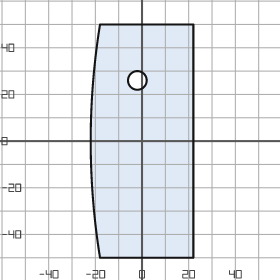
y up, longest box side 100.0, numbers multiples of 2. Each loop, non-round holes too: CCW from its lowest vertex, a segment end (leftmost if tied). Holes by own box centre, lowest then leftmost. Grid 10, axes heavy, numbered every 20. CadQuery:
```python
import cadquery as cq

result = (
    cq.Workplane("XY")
    .moveTo(-18.0, -50.0)
    .lineTo(22.0, -50.0)
    .lineTo(22.0, 50.0)
    .lineTo(-18.0, 50.0)
    .threePointArc((-22.0, 0.0), (-18.0, -50.0))
    .close()
    .moveTo(-2.0, 26.0)
    .circle(4.0)
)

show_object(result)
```